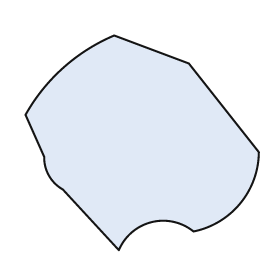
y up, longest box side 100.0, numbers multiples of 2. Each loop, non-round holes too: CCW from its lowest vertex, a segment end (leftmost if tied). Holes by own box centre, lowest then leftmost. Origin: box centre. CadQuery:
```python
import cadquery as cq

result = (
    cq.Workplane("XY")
    .moveTo(-10.0, -46.0)
    .threePointArc((4.0, -34.0), (22.0, -38.0))
    .threePointArc((42.0, -26.0), (50.0, -4.0))
    .lineTo(20.0, 34.0)
    .lineTo(-12.0, 46.0)
    .threePointArc((-34.0, 32.0), (-50.0, 12.0))
    .lineTo(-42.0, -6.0)
    .threePointArc((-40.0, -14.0), (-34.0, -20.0))
    .close()
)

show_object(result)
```